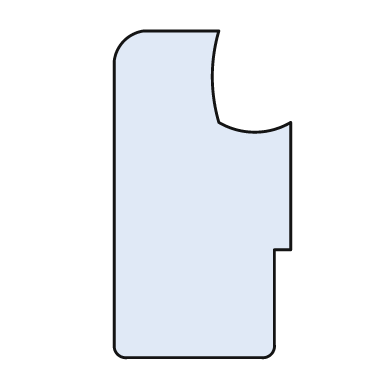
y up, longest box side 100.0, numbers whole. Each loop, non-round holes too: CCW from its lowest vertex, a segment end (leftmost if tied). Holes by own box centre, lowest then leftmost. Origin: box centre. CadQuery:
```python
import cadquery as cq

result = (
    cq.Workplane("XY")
    .moveTo(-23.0, -50.0)
    .lineTo(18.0, -50.0)
    .threePointArc((21.0, -49.0), (22.0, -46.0))
    .lineTo(22.0, -17.0)
    .lineTo(27.0, -17.0)
    .lineTo(27.0, 22.0)
    .threePointArc((16.0, 19.0), (5.0, 22.0))
    .threePointArc((3.0, 36.0), (5.0, 50.0))
    .lineTo(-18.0, 50.0)
    .threePointArc((-24.0, 47.0), (-27.0, 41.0))
    .lineTo(-27.0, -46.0)
    .threePointArc((-26.0, -49.0), (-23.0, -50.0))
    .close()
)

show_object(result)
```